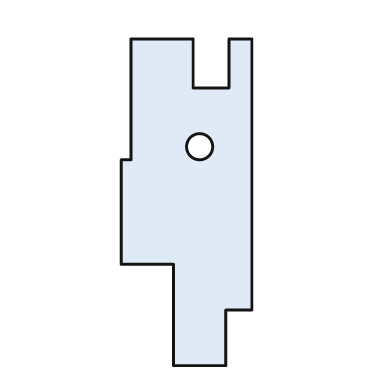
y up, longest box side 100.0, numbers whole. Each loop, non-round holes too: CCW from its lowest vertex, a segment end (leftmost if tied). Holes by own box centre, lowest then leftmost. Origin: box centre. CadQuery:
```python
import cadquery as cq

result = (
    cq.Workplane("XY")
    .moveTo(-4.0, -50.0)
    .lineTo(12.0, -50.0)
    .lineTo(12.0, -33.0)
    .lineTo(20.0, -33.0)
    .lineTo(20.0, 50.0)
    .lineTo(13.0, 50.0)
    .lineTo(13.0, 35.0)
    .lineTo(2.0, 35.0)
    .lineTo(2.0, 50.0)
    .lineTo(-17.0, 50.0)
    .lineTo(-17.0, 13.0)
    .lineTo(-20.0, 13.0)
    .lineTo(-20.0, -19.0)
    .lineTo(-4.0, -19.0)
    .close()
    .moveTo(4.0, 17.0)
    .circle(4.0)
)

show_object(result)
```